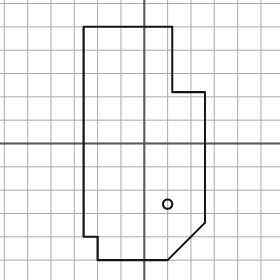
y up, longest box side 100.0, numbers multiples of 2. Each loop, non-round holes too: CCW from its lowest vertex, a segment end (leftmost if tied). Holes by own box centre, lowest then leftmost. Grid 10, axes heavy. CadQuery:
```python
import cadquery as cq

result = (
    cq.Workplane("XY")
    .moveTo(-20.0, -50.0)
    .lineTo(10.0, -50.0)
    .lineTo(26.0, -34.0)
    .lineTo(26.0, 22.0)
    .lineTo(12.0, 22.0)
    .lineTo(12.0, 50.0)
    .lineTo(-26.0, 50.0)
    .lineTo(-26.0, -40.0)
    .lineTo(-20.0, -40.0)
    .close()
    .moveTo(10.0, -26.0)
    .circle(2.0)
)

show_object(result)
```